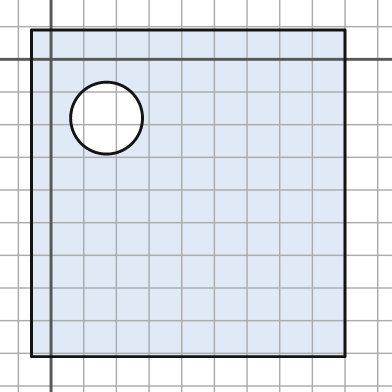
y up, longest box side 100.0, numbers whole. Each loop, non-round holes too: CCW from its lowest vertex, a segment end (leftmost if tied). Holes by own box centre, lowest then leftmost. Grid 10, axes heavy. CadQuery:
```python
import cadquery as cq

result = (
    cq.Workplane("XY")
    .moveTo(-6.0, -91.0)
    .lineTo(90.0, -91.0)
    .lineTo(90.0, 9.0)
    .lineTo(-6.0, 9.0)
    .close()
    .moveTo(17.0, -18.0)
    .circle(11.0)
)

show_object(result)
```